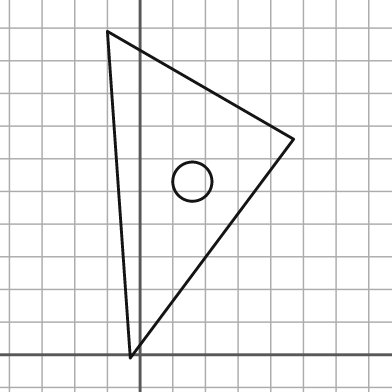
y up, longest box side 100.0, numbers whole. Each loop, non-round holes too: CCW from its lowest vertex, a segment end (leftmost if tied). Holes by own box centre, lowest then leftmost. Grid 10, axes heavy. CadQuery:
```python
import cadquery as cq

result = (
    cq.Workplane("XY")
    .moveTo(-3.0, -1.0)
    .lineTo(47.0, 66.0)
    .lineTo(-10.0, 99.0)
    .close()
    .moveTo(16.0, 53.0)
    .circle(6.0)
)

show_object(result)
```